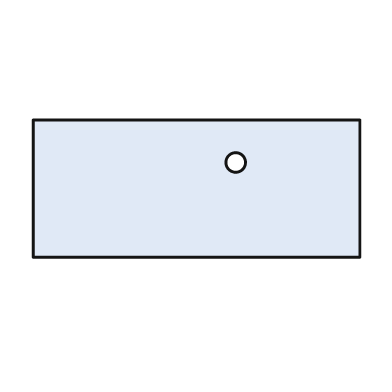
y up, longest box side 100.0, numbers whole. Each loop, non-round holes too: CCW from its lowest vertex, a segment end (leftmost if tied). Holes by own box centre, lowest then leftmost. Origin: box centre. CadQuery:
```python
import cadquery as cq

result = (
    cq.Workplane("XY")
    .moveTo(-50.0, -21.0)
    .lineTo(50.0, -21.0)
    .lineTo(50.0, 21.0)
    .lineTo(-50.0, 21.0)
    .close()
    .moveTo(12.0, 8.0)
    .circle(3.0)
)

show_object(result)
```